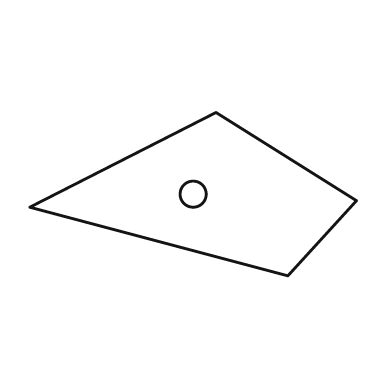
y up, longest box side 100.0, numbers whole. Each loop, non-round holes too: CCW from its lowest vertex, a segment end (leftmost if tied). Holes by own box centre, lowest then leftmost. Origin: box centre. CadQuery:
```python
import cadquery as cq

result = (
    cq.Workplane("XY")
    .moveTo(29.0, -25.0)
    .lineTo(50.0, -2.0)
    .lineTo(7.0, 25.0)
    .lineTo(-50.0, -4.0)
    .close()
    .moveTo(0.0, 0.0)
    .circle(4.0)
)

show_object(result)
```